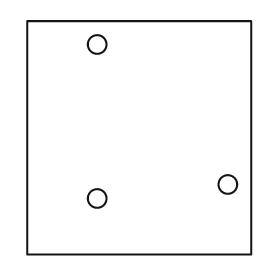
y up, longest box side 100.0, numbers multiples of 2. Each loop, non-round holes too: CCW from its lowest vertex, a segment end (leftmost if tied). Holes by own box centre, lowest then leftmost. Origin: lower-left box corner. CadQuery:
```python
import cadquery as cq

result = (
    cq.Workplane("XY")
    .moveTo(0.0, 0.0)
    .lineTo(96.0, 0.0)
    .lineTo(96.0, 100.0)
    .lineTo(0.0, 100.0)
    .close()
    .moveTo(30.0, 24.0)
    .circle(4.0)
    .moveTo(86.0, 30.0)
    .circle(4.0)
    .moveTo(30.0, 90.0)
    .circle(4.0)
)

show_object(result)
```